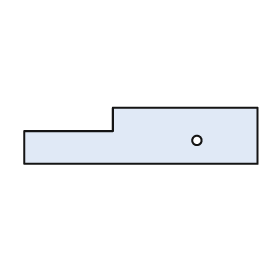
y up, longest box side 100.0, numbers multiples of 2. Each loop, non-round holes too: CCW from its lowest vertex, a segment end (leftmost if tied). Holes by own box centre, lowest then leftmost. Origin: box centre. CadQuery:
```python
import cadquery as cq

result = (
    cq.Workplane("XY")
    .moveTo(-50.0, -12.0)
    .lineTo(50.0, -12.0)
    .lineTo(50.0, 12.0)
    .lineTo(-12.0, 12.0)
    .lineTo(-12.0, 2.0)
    .lineTo(-50.0, 2.0)
    .close()
    .moveTo(24.0, -2.0)
    .circle(2.0)
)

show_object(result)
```